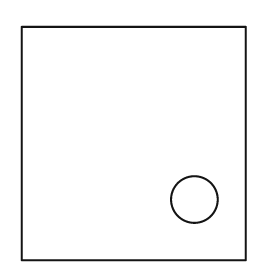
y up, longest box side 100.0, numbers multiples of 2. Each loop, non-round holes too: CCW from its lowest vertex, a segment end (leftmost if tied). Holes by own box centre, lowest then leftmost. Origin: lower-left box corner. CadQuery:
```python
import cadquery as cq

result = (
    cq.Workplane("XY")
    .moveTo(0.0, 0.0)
    .lineTo(96.0, 0.0)
    .lineTo(96.0, 100.0)
    .lineTo(0.0, 100.0)
    .close()
    .moveTo(74.0, 26.0)
    .circle(10.0)
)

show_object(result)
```